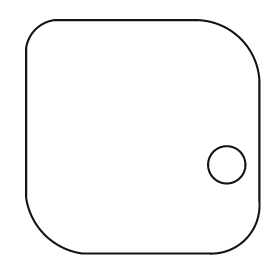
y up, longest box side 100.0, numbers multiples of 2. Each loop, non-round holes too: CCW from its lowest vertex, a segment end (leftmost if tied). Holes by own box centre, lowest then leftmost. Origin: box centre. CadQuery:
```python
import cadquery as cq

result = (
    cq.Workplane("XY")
    .moveTo(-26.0, -50.0)
    .lineTo(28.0, -50.0)
    .threePointArc((44.0, -44.0), (50.0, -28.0))
    .lineTo(50.0, 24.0)
    .threePointArc((42.0, 42.0), (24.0, 50.0))
    .lineTo(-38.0, 50.0)
    .threePointArc((-46.0, 46.0), (-50.0, 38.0))
    .lineTo(-50.0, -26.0)
    .threePointArc((-42.0, -42.0), (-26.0, -50.0))
    .close()
    .moveTo(36.0, -12.0)
    .circle(8.0)
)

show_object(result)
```